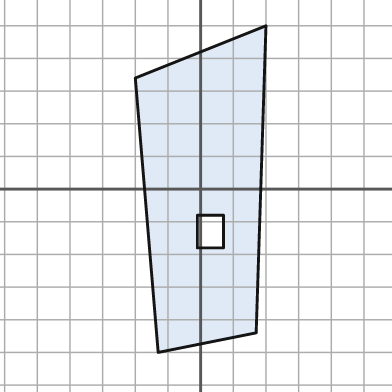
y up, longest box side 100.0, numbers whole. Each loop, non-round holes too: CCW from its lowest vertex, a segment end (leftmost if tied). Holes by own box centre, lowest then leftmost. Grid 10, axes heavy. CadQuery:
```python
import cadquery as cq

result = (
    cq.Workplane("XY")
    .moveTo(-13.0, -50.0)
    .lineTo(17.0, -44.0)
    .lineTo(20.0, 50.0)
    .lineTo(-20.0, 34.0)
    .close()
    .moveTo(-1.0, -18.0)
    .lineTo(7.0, -18.0)
    .lineTo(7.0, -8.0)
    .lineTo(-1.0, -8.0)
    .close()
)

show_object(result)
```